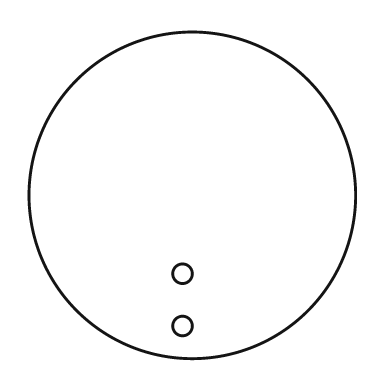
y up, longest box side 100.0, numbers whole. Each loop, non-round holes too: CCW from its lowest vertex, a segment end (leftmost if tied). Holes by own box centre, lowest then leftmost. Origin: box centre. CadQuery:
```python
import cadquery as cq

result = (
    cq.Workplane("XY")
    .moveTo(0.0, 0.0)
    .circle(50.0)
    .moveTo(-3.0, -40.0)
    .circle(3.0)
    .moveTo(-3.0, -24.0)
    .circle(3.0)
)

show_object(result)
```